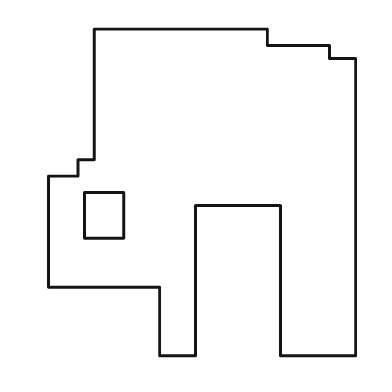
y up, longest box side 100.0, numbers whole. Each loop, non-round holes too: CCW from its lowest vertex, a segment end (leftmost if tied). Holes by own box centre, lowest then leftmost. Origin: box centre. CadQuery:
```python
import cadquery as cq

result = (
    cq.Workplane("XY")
    .moveTo(-13.0, -50.0)
    .lineTo(-2.0, -50.0)
    .lineTo(-2.0, -4.0)
    .lineTo(24.0, -4.0)
    .lineTo(24.0, -50.0)
    .lineTo(47.0, -50.0)
    .lineTo(47.0, 41.0)
    .lineTo(39.0, 41.0)
    .lineTo(39.0, 45.0)
    .lineTo(20.0, 45.0)
    .lineTo(20.0, 50.0)
    .lineTo(-33.0, 50.0)
    .lineTo(-33.0, 10.0)
    .lineTo(-38.0, 10.0)
    .lineTo(-38.0, 5.0)
    .lineTo(-47.0, 5.0)
    .lineTo(-47.0, -29.0)
    .lineTo(-13.0, -29.0)
    .close()
    .moveTo(-36.0, -14.0)
    .lineTo(-24.0, -14.0)
    .lineTo(-24.0, 0.0)
    .lineTo(-36.0, 0.0)
    .close()
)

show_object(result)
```